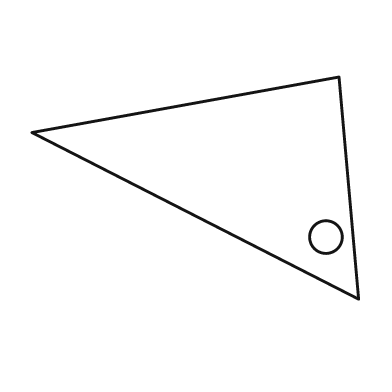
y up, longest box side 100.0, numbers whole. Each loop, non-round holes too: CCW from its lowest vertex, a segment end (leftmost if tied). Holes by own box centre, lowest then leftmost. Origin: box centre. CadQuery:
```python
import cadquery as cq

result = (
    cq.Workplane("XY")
    .moveTo(50.0, -34.0)
    .lineTo(44.0, 34.0)
    .lineTo(-50.0, 17.0)
    .close()
    .moveTo(40.0, -15.0)
    .circle(5.0)
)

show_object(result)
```